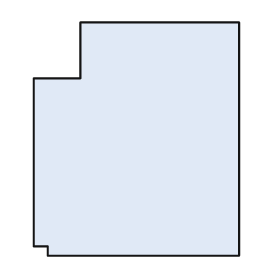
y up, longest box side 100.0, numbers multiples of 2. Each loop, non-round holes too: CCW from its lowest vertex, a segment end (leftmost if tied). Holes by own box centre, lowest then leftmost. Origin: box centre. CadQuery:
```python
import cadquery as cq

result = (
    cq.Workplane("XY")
    .moveTo(-38.0, -50.0)
    .lineTo(44.0, -50.0)
    .lineTo(44.0, 50.0)
    .lineTo(-24.0, 50.0)
    .lineTo(-24.0, 26.0)
    .lineTo(-44.0, 26.0)
    .lineTo(-44.0, -46.0)
    .lineTo(-38.0, -46.0)
    .close()
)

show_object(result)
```